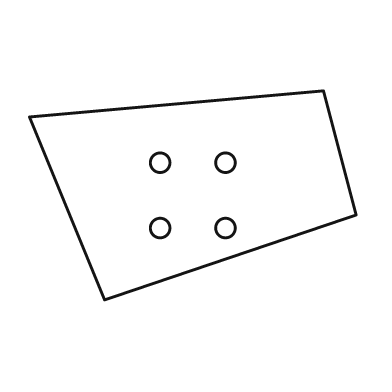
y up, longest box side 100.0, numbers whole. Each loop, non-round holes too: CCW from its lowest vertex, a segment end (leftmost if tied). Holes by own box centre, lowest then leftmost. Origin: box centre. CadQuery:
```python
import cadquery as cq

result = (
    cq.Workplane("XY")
    .moveTo(-27.0, -32.0)
    .lineTo(50.0, -6.0)
    .lineTo(40.0, 32.0)
    .lineTo(-50.0, 24.0)
    .close()
    .moveTo(-10.0, -10.0)
    .circle(3.0)
    .moveTo(10.0, -10.0)
    .circle(3.0)
    .moveTo(-10.0, 10.0)
    .circle(3.0)
    .moveTo(10.0, 10.0)
    .circle(3.0)
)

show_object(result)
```